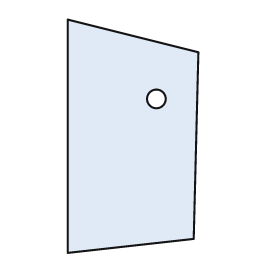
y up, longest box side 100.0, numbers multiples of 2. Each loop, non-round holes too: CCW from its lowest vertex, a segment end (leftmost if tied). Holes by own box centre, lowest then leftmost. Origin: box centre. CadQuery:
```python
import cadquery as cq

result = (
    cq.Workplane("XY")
    .moveTo(-28.0, -50.0)
    .lineTo(26.0, -44.0)
    .lineTo(28.0, 36.0)
    .lineTo(-28.0, 50.0)
    .close()
    .moveTo(10.0, 16.0)
    .circle(4.0)
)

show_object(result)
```